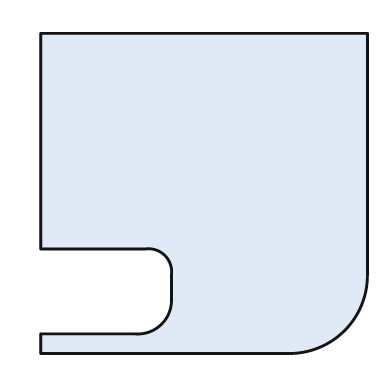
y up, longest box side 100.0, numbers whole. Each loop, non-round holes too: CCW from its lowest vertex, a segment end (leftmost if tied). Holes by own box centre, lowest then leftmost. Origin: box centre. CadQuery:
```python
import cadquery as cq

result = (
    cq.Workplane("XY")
    .moveTo(-50.0, -49.0)
    .lineTo(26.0, -49.0)
    .threePointArc((43.0, -42.0), (50.0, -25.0))
    .lineTo(50.0, 49.0)
    .lineTo(-50.0, 49.0)
    .lineTo(-50.0, -17.0)
    .lineTo(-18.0, -17.0)
    .threePointArc((-12.0, -19.0), (-10.0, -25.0))
    .lineTo(-10.0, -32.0)
    .threePointArc((-13.0, -40.0), (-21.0, -43.0))
    .lineTo(-50.0, -43.0)
    .close()
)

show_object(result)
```